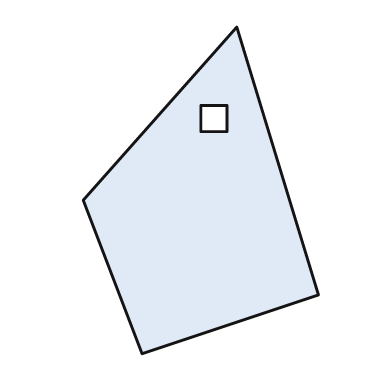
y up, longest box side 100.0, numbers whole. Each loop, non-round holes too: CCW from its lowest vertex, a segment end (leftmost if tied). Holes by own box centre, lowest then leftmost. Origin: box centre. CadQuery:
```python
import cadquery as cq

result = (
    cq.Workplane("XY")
    .moveTo(-18.0, -50.0)
    .lineTo(36.0, -32.0)
    .lineTo(11.0, 50.0)
    .lineTo(-36.0, -3.0)
    .close()
    .moveTo(0.0, 18.0)
    .lineTo(8.0, 18.0)
    .lineTo(8.0, 26.0)
    .lineTo(0.0, 26.0)
    .close()
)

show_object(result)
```